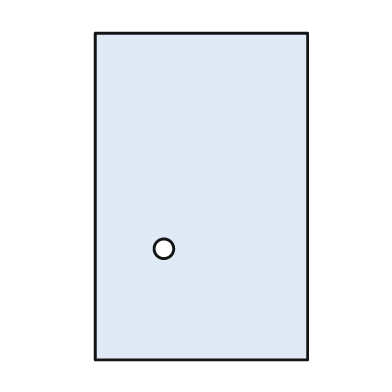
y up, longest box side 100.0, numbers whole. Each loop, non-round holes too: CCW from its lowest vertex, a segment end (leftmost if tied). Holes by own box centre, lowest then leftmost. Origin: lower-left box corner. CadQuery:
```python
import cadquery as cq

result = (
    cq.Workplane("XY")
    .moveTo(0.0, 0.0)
    .lineTo(65.0, 0.0)
    .lineTo(65.0, 100.0)
    .lineTo(0.0, 100.0)
    .close()
    .moveTo(21.0, 34.0)
    .circle(3.0)
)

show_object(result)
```